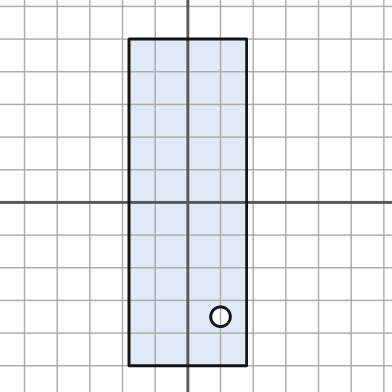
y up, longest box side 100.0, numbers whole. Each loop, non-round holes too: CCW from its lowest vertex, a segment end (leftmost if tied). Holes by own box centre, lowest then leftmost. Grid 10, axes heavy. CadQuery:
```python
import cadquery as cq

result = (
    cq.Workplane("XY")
    .moveTo(-18.0, -50.0)
    .lineTo(18.0, -50.0)
    .lineTo(18.0, 50.0)
    .lineTo(-18.0, 50.0)
    .close()
    .moveTo(10.0, -35.0)
    .circle(3.0)
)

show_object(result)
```